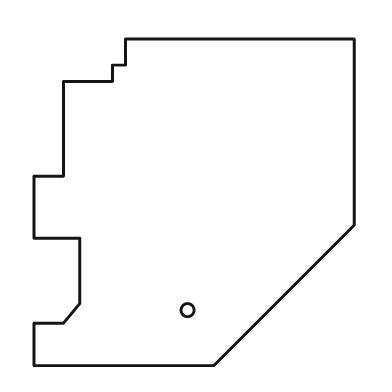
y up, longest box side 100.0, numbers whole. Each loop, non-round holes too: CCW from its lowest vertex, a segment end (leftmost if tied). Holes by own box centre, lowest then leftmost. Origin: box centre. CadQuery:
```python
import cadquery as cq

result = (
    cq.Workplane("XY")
    .moveTo(-49.0, -50.0)
    .lineTo(6.0, -50.0)
    .lineTo(49.0, -7.0)
    .lineTo(49.0, 50.0)
    .lineTo(-21.0, 50.0)
    .lineTo(-21.0, 42.0)
    .lineTo(-25.0, 42.0)
    .lineTo(-25.0, 37.0)
    .lineTo(-40.0, 37.0)
    .lineTo(-40.0, 8.0)
    .lineTo(-49.0, 8.0)
    .lineTo(-49.0, -11.0)
    .lineTo(-35.0, -11.0)
    .lineTo(-35.0, -31.0)
    .lineTo(-40.0, -37.0)
    .lineTo(-49.0, -37.0)
    .close()
    .moveTo(-2.0, -33.0)
    .circle(2.0)
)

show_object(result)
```